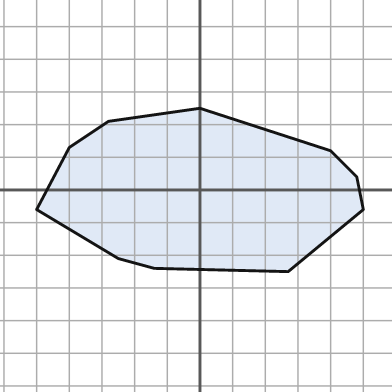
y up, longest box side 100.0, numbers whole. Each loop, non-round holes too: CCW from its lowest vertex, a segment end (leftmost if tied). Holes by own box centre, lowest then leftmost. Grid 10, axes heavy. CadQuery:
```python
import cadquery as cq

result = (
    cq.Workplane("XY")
    .moveTo(27.0, -25.0)
    .lineTo(50.0, -6.0)
    .lineTo(48.0, 4.0)
    .lineTo(40.0, 12.0)
    .lineTo(0.0, 25.0)
    .lineTo(-28.0, 21.0)
    .lineTo(-40.0, 13.0)
    .lineTo(-50.0, -6.0)
    .lineTo(-25.0, -21.0)
    .lineTo(-14.0, -24.0)
    .close()
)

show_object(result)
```